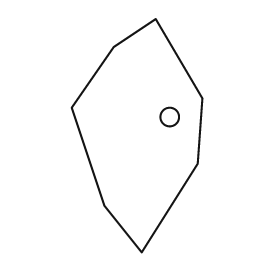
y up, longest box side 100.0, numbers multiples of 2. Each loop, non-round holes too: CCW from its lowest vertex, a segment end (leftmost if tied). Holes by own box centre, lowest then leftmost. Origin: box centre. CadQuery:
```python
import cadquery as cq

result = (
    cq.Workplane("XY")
    .moveTo(2.0, -50.0)
    .lineTo(26.0, -12.0)
    .lineTo(28.0, 16.0)
    .lineTo(8.0, 50.0)
    .lineTo(-10.0, 38.0)
    .lineTo(-28.0, 12.0)
    .lineTo(-14.0, -30.0)
    .close()
    .moveTo(14.0, 8.0)
    .circle(4.0)
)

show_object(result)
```